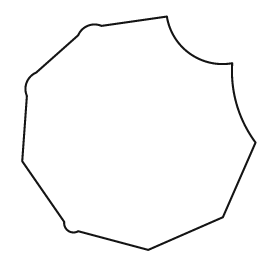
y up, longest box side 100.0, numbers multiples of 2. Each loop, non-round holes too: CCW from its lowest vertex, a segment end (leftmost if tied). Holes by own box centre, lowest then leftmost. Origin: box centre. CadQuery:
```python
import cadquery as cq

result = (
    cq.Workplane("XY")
    .moveTo(4.0, -50.0)
    .lineTo(36.0, -36.0)
    .lineTo(50.0, -4.0)
    .threePointArc((42.0, 12.0), (40.0, 30.0))
    .threePointArc((22.0, 34.0), (12.0, 50.0))
    .lineTo(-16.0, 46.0)
    .threePointArc((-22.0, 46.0), (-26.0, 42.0))
    .lineTo(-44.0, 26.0)
    .threePointArc((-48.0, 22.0), (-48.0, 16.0))
    .lineTo(-50.0, -12.0)
    .lineTo(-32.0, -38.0)
    .threePointArc((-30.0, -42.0), (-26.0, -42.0))
    .close()
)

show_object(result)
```